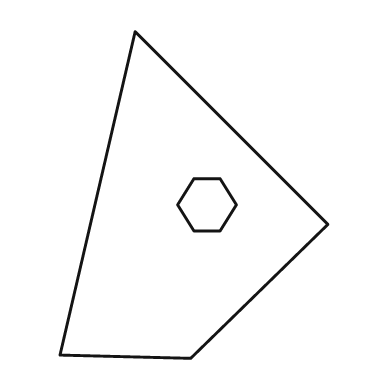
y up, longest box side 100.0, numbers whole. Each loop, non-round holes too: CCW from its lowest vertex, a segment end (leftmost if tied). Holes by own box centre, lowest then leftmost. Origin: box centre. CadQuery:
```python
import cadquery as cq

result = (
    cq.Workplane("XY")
    .moveTo(-1.0, -50.0)
    .lineTo(41.0, -9.0)
    .lineTo(-18.0, 50.0)
    .lineTo(-41.0, -49.0)
    .close()
    .moveTo(0.0, -11.0)
    .lineTo(8.0, -11.0)
    .lineTo(13.0, -3.0)
    .lineTo(8.0, 5.0)
    .lineTo(0.0, 5.0)
    .lineTo(-5.0, -3.0)
    .close()
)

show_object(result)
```